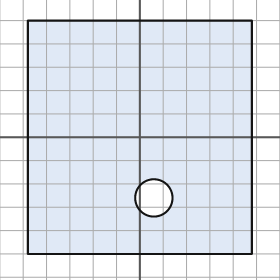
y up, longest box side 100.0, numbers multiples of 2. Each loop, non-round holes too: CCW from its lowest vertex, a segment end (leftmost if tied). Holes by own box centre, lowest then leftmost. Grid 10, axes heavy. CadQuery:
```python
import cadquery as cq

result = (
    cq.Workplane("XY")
    .moveTo(-48.0, -50.0)
    .lineTo(48.0, -50.0)
    .lineTo(48.0, 50.0)
    .lineTo(-48.0, 50.0)
    .close()
    .moveTo(6.0, -26.0)
    .circle(8.0)
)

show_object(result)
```